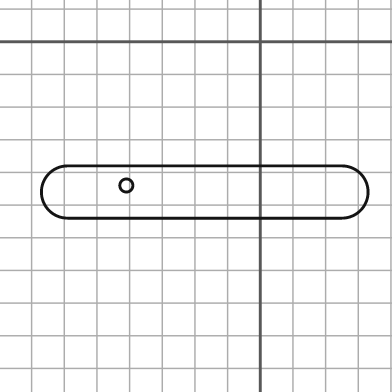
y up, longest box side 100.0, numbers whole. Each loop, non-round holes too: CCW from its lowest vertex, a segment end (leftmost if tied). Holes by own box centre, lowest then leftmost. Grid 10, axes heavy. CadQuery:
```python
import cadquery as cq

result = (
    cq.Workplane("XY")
    .moveTo(-59.0, -54.0)
    .lineTo(25.0, -54.0)
    .threePointArc((33.0, -46.0), (25.0, -38.0))
    .lineTo(-59.0, -38.0)
    .threePointArc((-67.0, -46.0), (-59.0, -54.0))
    .close()
    .moveTo(-41.0, -44.0)
    .circle(2.0)
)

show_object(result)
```